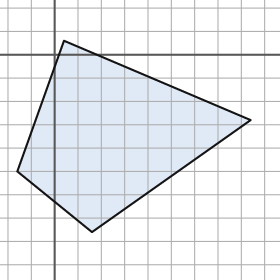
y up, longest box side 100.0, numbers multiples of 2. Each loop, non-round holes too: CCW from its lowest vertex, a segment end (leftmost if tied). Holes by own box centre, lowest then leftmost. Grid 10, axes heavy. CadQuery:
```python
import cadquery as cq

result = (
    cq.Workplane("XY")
    .moveTo(16.0, -76.0)
    .lineTo(84.0, -28.0)
    .lineTo(4.0, 6.0)
    .lineTo(-16.0, -50.0)
    .close()
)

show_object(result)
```